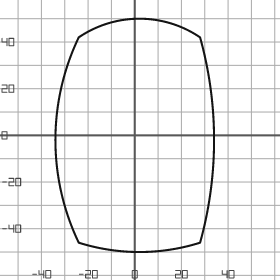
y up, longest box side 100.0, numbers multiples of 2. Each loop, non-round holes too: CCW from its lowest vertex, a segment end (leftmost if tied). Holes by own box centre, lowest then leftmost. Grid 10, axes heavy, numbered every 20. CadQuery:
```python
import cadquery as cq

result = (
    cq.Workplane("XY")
    .moveTo(-24.0, -46.0)
    .threePointArc((2.0, -50.0), (28.0, -46.0))
    .threePointArc((34.0, -2.0), (28.0, 42.0))
    .threePointArc((2.0, 50.0), (-24.0, 42.0))
    .threePointArc((-34.0, -2.0), (-24.0, -46.0))
    .close()
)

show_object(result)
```